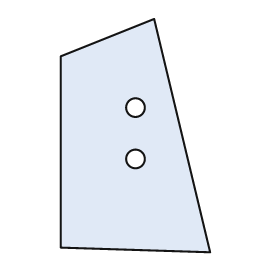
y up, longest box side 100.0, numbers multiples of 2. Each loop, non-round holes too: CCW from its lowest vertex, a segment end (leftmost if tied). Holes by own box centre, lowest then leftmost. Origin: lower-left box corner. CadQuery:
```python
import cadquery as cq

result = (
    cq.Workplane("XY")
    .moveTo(64.0, 0.0)
    .lineTo(40.0, 100.0)
    .lineTo(0.0, 84.0)
    .lineTo(0.0, 2.0)
    .close()
    .moveTo(32.0, 40.0)
    .circle(4.0)
    .moveTo(32.0, 62.0)
    .circle(4.0)
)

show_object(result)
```